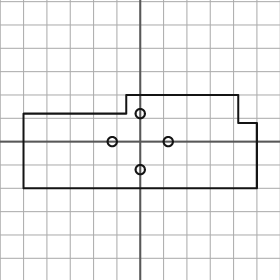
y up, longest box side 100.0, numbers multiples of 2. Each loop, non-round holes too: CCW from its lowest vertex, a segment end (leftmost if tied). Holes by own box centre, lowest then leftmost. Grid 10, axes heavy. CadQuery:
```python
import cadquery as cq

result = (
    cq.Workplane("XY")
    .moveTo(-50.0, -20.0)
    .lineTo(50.0, -20.0)
    .lineTo(50.0, 8.0)
    .lineTo(42.0, 8.0)
    .lineTo(42.0, 20.0)
    .lineTo(-6.0, 20.0)
    .lineTo(-6.0, 12.0)
    .lineTo(-50.0, 12.0)
    .close()
    .moveTo(0.0, -12.0)
    .circle(2.0)
    .moveTo(-12.0, 0.0)
    .circle(2.0)
    .moveTo(12.0, 0.0)
    .circle(2.0)
    .moveTo(0.0, 12.0)
    .circle(2.0)
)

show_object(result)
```